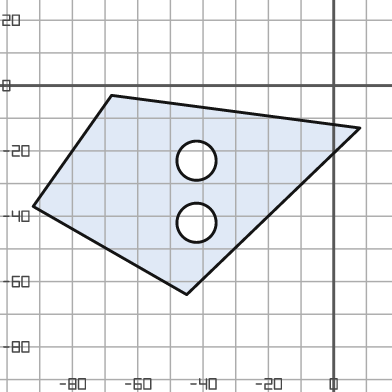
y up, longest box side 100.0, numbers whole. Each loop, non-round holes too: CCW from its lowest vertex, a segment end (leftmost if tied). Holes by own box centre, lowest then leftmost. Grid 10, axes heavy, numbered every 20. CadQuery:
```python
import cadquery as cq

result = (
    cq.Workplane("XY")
    .moveTo(-45.0, -64.0)
    .lineTo(8.0, -13.0)
    .lineTo(-68.0, -3.0)
    .lineTo(-92.0, -37.0)
    .close()
    .moveTo(-42.0, -42.0)
    .circle(6.0)
    .moveTo(-42.0, -23.0)
    .circle(6.0)
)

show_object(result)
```